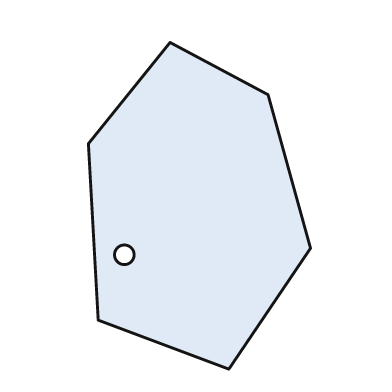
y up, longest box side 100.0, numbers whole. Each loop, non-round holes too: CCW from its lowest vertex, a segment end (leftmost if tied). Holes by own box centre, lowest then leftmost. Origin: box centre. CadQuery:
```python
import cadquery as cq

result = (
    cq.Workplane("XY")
    .moveTo(9.0, -50.0)
    .lineTo(34.0, -13.0)
    .lineTo(21.0, 34.0)
    .lineTo(-9.0, 50.0)
    .lineTo(-34.0, 19.0)
    .lineTo(-31.0, -35.0)
    .close()
    .moveTo(-23.0, -15.0)
    .circle(3.0)
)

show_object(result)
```